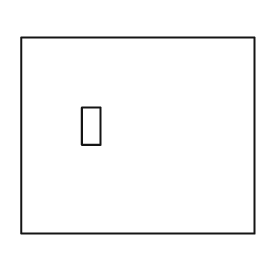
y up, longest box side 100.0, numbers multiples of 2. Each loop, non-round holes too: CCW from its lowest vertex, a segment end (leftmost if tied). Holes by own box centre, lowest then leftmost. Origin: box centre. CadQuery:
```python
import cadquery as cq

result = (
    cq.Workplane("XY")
    .moveTo(-50.0, -42.0)
    .lineTo(50.0, -42.0)
    .lineTo(50.0, 42.0)
    .lineTo(-50.0, 42.0)
    .close()
    .moveTo(-24.0, -4.0)
    .lineTo(-16.0, -4.0)
    .lineTo(-16.0, 12.0)
    .lineTo(-24.0, 12.0)
    .close()
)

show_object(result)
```